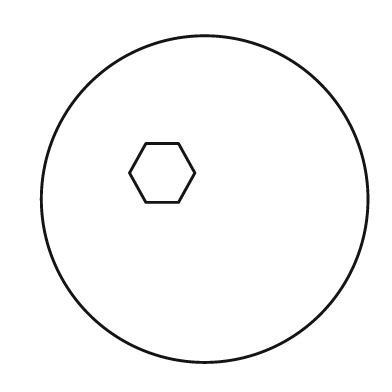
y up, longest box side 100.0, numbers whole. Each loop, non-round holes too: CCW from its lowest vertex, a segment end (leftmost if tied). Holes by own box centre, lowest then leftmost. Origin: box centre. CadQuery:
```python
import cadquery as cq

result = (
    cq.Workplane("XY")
    .moveTo(0.0, 0.0)
    .circle(50.0)
    .moveTo(-18.0, -1.0)
    .lineTo(-8.0, -1.0)
    .lineTo(-3.0, 8.0)
    .lineTo(-8.0, 17.0)
    .lineTo(-18.0, 17.0)
    .lineTo(-23.0, 8.0)
    .close()
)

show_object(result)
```